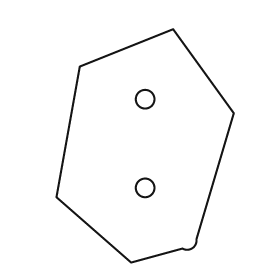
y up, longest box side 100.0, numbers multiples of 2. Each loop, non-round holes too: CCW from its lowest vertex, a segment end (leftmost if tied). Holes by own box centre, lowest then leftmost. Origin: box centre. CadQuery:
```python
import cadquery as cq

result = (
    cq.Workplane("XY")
    .moveTo(-6.0, -50.0)
    .lineTo(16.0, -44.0)
    .threePointArc((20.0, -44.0), (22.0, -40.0))
    .lineTo(38.0, 14.0)
    .lineTo(12.0, 50.0)
    .lineTo(-28.0, 34.0)
    .lineTo(-38.0, -22.0)
    .close()
    .moveTo(0.0, -18.0)
    .circle(4.0)
    .moveTo(0.0, 20.0)
    .circle(4.0)
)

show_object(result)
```